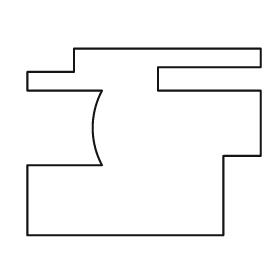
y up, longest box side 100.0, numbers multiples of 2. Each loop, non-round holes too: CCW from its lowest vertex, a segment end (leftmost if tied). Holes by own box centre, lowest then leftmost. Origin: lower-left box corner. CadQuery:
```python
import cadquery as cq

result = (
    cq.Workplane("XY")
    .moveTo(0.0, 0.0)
    .lineTo(84.0, 0.0)
    .lineTo(84.0, 34.0)
    .lineTo(100.0, 34.0)
    .lineTo(100.0, 62.0)
    .lineTo(56.0, 62.0)
    .lineTo(56.0, 72.0)
    .lineTo(100.0, 72.0)
    .lineTo(100.0, 80.0)
    .lineTo(20.0, 80.0)
    .lineTo(20.0, 70.0)
    .lineTo(0.0, 70.0)
    .lineTo(0.0, 62.0)
    .lineTo(32.0, 62.0)
    .threePointArc((28.0, 46.0), (32.0, 30.0))
    .lineTo(0.0, 30.0)
    .close()
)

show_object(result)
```